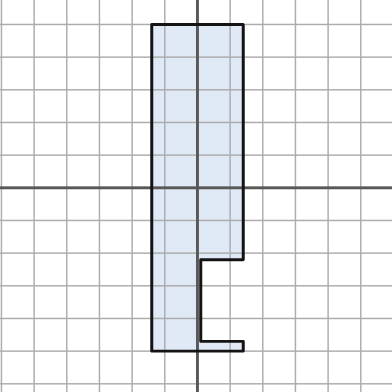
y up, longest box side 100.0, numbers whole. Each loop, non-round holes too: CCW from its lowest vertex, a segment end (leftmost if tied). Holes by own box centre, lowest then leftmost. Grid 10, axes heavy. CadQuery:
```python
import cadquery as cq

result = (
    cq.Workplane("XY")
    .moveTo(-14.0, -50.0)
    .lineTo(14.0, -50.0)
    .lineTo(14.0, -47.0)
    .lineTo(1.0, -47.0)
    .lineTo(1.0, -22.0)
    .lineTo(14.0, -22.0)
    .lineTo(14.0, 50.0)
    .lineTo(-14.0, 50.0)
    .close()
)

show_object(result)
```